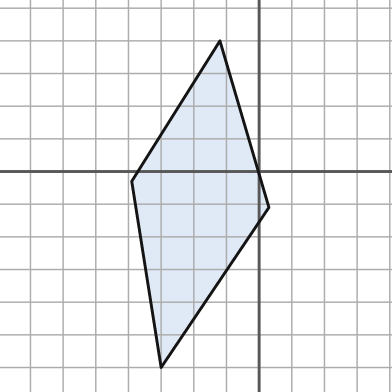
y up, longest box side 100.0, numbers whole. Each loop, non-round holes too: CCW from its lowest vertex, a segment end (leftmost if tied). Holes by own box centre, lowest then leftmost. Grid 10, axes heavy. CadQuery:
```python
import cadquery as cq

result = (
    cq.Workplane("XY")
    .moveTo(-30.0, -60.0)
    .lineTo(3.0, -11.0)
    .lineTo(-12.0, 40.0)
    .lineTo(-39.0, -3.0)
    .close()
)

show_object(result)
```